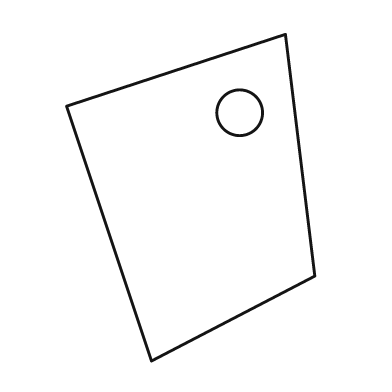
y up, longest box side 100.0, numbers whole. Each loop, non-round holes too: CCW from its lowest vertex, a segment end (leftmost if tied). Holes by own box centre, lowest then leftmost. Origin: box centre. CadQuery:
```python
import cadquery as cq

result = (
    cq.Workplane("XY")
    .moveTo(-12.0, -50.0)
    .lineTo(38.0, -24.0)
    .lineTo(29.0, 50.0)
    .lineTo(-38.0, 28.0)
    .close()
    .moveTo(15.0, 26.0)
    .circle(7.0)
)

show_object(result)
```